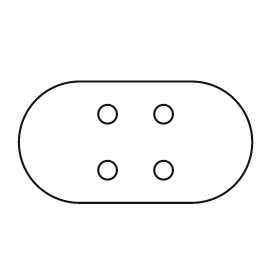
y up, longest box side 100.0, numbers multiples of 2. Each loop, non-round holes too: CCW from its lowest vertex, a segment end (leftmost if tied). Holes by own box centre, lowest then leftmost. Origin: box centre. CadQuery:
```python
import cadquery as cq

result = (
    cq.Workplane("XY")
    .moveTo(-24.0, -26.0)
    .lineTo(24.0, -26.0)
    .threePointArc((50.0, 0.0), (24.0, 26.0))
    .lineTo(-24.0, 26.0)
    .threePointArc((-50.0, 0.0), (-24.0, -26.0))
    .close()
    .moveTo(-12.0, -12.0)
    .circle(4.0)
    .moveTo(12.0, -12.0)
    .circle(4.0)
    .moveTo(-12.0, 12.0)
    .circle(4.0)
    .moveTo(12.0, 12.0)
    .circle(4.0)
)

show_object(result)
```